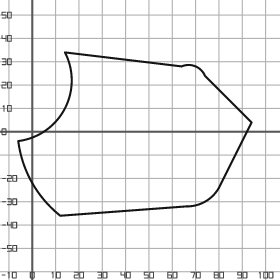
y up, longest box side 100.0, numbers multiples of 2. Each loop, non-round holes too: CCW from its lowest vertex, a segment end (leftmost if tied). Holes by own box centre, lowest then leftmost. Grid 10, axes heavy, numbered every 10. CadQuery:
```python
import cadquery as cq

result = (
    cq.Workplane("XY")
    .moveTo(12.0, -36.0)
    .lineTo(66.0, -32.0)
    .threePointArc((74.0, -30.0), (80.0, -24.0))
    .lineTo(94.0, 4.0)
    .lineTo(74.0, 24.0)
    .threePointArc((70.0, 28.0), (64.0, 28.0))
    .lineTo(14.0, 34.0)
    .threePointArc((14.0, 10.0), (-6.0, -4.0))
    .threePointArc((0.0, -22.0), (12.0, -36.0))
    .close()
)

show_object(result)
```